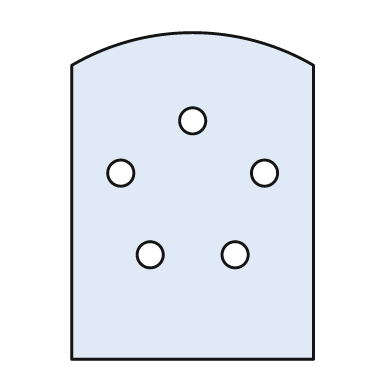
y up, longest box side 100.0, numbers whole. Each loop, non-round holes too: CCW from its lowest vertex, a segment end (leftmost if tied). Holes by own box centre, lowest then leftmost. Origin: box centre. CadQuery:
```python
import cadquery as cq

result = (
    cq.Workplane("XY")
    .moveTo(-37.0, -50.0)
    .lineTo(37.0, -50.0)
    .lineTo(37.0, 40.0)
    .threePointArc((0.0, 50.0), (-37.0, 40.0))
    .close()
    .moveTo(-13.0, -18.0)
    .circle(4.0)
    .moveTo(13.0, -18.0)
    .circle(4.0)
    .moveTo(-22.0, 7.0)
    .circle(4.0)
    .moveTo(22.0, 7.0)
    .circle(4.0)
    .moveTo(0.0, 23.0)
    .circle(4.0)
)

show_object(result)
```